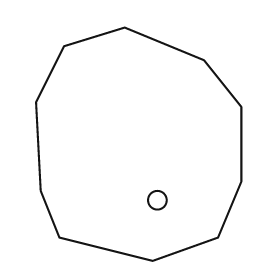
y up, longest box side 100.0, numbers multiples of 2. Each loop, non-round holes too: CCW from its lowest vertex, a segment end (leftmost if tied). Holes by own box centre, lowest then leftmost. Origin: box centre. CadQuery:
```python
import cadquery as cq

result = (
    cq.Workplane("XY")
    .moveTo(6.0, -50.0)
    .lineTo(34.0, -40.0)
    .lineTo(44.0, -16.0)
    .lineTo(44.0, 16.0)
    .lineTo(28.0, 36.0)
    .lineTo(-6.0, 50.0)
    .lineTo(-32.0, 42.0)
    .lineTo(-44.0, 18.0)
    .lineTo(-42.0, -20.0)
    .lineTo(-34.0, -40.0)
    .close()
    .moveTo(8.0, -24.0)
    .circle(4.0)
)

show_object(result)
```